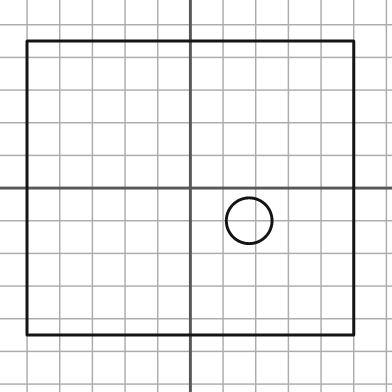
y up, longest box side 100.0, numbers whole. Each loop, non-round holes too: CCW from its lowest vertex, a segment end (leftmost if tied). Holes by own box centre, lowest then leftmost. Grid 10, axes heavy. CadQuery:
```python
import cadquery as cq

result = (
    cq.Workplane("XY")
    .moveTo(-50.0, -45.0)
    .lineTo(50.0, -45.0)
    .lineTo(50.0, 45.0)
    .lineTo(-50.0, 45.0)
    .close()
    .moveTo(18.0, -10.0)
    .circle(7.0)
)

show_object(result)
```